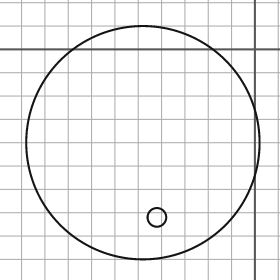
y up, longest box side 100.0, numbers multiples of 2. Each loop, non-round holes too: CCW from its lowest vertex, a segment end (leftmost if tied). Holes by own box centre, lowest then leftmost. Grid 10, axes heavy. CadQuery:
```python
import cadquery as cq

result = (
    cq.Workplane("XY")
    .moveTo(-48.0, -40.0)
    .circle(50.0)
    .moveTo(-42.0, -72.0)
    .circle(4.0)
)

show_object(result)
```